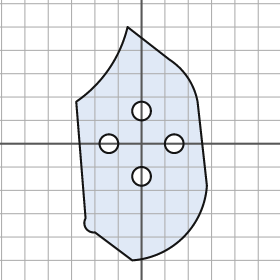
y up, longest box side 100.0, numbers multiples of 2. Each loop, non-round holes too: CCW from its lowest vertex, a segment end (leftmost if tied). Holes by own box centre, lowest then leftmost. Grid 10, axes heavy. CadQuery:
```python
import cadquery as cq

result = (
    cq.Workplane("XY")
    .moveTo(-4.0, -50.0)
    .threePointArc((18.0, -40.0), (28.0, -18.0))
    .lineTo(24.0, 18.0)
    .threePointArc((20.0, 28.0), (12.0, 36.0))
    .lineTo(-6.0, 50.0)
    .threePointArc((-14.0, 32.0), (-28.0, 18.0))
    .lineTo(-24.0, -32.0)
    .threePointArc((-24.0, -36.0), (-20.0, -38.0))
    .close()
    .moveTo(0.0, -14.0)
    .circle(4.0)
    .moveTo(-14.0, 0.0)
    .circle(4.0)
    .moveTo(14.0, 0.0)
    .circle(4.0)
    .moveTo(0.0, 14.0)
    .circle(4.0)
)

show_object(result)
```